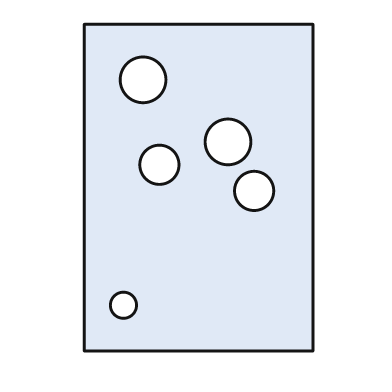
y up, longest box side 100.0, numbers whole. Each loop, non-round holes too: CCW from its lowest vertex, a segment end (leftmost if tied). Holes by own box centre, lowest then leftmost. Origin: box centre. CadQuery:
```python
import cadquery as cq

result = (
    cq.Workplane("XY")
    .moveTo(-35.0, -50.0)
    .lineTo(35.0, -50.0)
    .lineTo(35.0, 50.0)
    .lineTo(-35.0, 50.0)
    .close()
    .moveTo(-23.0, -36.0)
    .circle(4.0)
    .moveTo(17.0, -1.0)
    .circle(6.0)
    .moveTo(-12.0, 7.0)
    .circle(6.0)
    .moveTo(9.0, 14.0)
    .circle(7.0)
    .moveTo(-17.0, 33.0)
    .circle(7.0)
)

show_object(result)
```